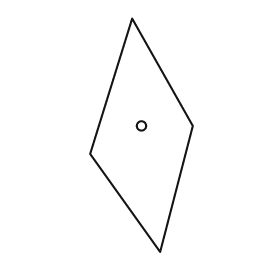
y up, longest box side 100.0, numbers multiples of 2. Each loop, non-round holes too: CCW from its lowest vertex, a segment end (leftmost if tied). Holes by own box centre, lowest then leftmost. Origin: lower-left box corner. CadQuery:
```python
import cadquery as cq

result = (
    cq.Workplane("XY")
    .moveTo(30.0, 0.0)
    .lineTo(44.0, 54.0)
    .lineTo(18.0, 100.0)
    .lineTo(0.0, 42.0)
    .close()
    .moveTo(22.0, 54.0)
    .circle(2.0)
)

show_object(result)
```